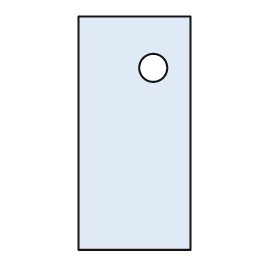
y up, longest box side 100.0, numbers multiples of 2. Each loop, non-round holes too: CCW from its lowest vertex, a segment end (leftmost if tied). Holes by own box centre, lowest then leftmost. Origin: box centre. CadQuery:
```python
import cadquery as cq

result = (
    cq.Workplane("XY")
    .moveTo(-24.0, -50.0)
    .lineTo(24.0, -50.0)
    .lineTo(24.0, 50.0)
    .lineTo(-24.0, 50.0)
    .close()
    .moveTo(8.0, 28.0)
    .circle(6.0)
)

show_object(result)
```